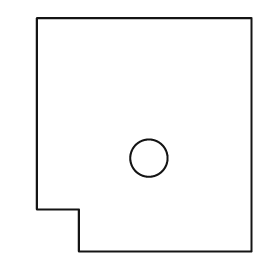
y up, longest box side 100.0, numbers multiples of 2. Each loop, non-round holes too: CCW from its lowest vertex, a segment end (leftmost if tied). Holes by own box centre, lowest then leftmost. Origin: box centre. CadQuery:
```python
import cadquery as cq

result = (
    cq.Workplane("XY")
    .moveTo(-28.0, -50.0)
    .lineTo(46.0, -50.0)
    .lineTo(46.0, 50.0)
    .lineTo(-46.0, 50.0)
    .lineTo(-46.0, -32.0)
    .lineTo(-28.0, -32.0)
    .close()
    .moveTo(2.0, -10.0)
    .circle(8.0)
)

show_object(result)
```